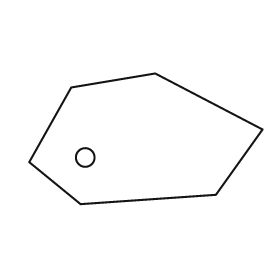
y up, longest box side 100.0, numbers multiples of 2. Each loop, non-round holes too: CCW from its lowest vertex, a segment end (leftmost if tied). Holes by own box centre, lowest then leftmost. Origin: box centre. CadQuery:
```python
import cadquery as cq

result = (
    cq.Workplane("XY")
    .moveTo(-28.0, -28.0)
    .lineTo(30.0, -24.0)
    .lineTo(50.0, 4.0)
    .lineTo(4.0, 28.0)
    .lineTo(-32.0, 22.0)
    .lineTo(-50.0, -10.0)
    .close()
    .moveTo(-26.0, -8.0)
    .circle(4.0)
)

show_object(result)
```